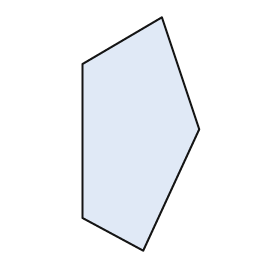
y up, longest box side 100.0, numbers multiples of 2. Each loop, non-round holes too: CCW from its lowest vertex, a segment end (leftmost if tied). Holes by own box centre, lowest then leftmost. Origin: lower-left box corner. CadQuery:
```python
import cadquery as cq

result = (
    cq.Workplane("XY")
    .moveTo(26.0, 0.0)
    .lineTo(50.0, 52.0)
    .lineTo(34.0, 100.0)
    .lineTo(0.0, 80.0)
    .lineTo(0.0, 14.0)
    .close()
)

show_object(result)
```